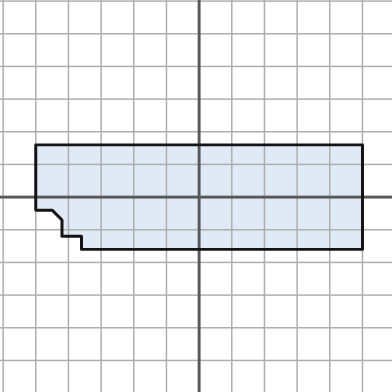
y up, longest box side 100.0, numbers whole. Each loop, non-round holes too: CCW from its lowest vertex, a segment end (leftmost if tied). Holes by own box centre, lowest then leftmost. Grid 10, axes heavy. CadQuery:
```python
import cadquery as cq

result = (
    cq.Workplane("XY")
    .moveTo(-36.0, -16.0)
    .lineTo(50.0, -16.0)
    .lineTo(50.0, 16.0)
    .lineTo(-50.0, 16.0)
    .lineTo(-50.0, -4.0)
    .lineTo(-45.0, -4.0)
    .lineTo(-42.0, -7.0)
    .lineTo(-42.0, -12.0)
    .lineTo(-36.0, -12.0)
    .close()
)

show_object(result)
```